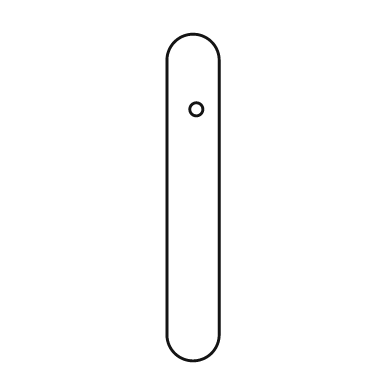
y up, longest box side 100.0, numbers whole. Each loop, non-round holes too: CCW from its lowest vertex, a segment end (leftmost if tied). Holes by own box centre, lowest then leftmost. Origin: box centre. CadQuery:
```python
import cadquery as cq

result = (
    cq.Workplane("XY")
    .moveTo(-8.0, -42.0)
    .threePointArc((0.0, -50.0), (8.0, -42.0))
    .lineTo(8.0, 42.0)
    .threePointArc((0.0, 50.0), (-8.0, 42.0))
    .close()
    .moveTo(1.0, 27.0)
    .circle(2.0)
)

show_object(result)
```